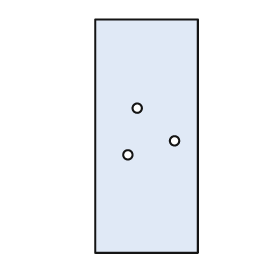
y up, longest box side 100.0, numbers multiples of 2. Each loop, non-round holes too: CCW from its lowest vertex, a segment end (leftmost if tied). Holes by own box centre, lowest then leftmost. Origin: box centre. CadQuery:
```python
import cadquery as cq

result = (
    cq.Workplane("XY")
    .moveTo(-22.0, -50.0)
    .lineTo(22.0, -50.0)
    .lineTo(22.0, 50.0)
    .lineTo(-22.0, 50.0)
    .close()
    .moveTo(-8.0, -8.0)
    .circle(2.0)
    .moveTo(12.0, -2.0)
    .circle(2.0)
    .moveTo(-4.0, 12.0)
    .circle(2.0)
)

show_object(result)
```